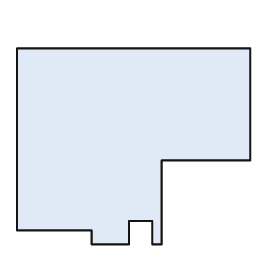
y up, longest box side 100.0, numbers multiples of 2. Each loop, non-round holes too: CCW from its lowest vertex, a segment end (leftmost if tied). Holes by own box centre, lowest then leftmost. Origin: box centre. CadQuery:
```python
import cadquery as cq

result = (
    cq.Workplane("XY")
    .moveTo(-18.0, -42.0)
    .lineTo(-2.0, -42.0)
    .lineTo(-2.0, -32.0)
    .lineTo(8.0, -32.0)
    .lineTo(8.0, -42.0)
    .lineTo(12.0, -42.0)
    .lineTo(12.0, -6.0)
    .lineTo(50.0, -6.0)
    .lineTo(50.0, 42.0)
    .lineTo(-50.0, 42.0)
    .lineTo(-50.0, -36.0)
    .lineTo(-18.0, -36.0)
    .close()
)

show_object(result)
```